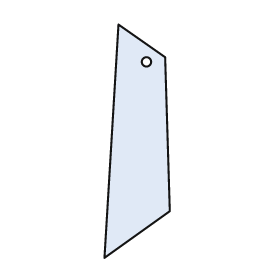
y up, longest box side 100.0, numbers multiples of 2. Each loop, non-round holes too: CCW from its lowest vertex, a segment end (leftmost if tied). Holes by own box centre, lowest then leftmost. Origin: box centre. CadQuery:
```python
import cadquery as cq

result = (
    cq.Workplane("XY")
    .moveTo(-14.0, -50.0)
    .lineTo(14.0, -30.0)
    .lineTo(12.0, 36.0)
    .lineTo(-8.0, 50.0)
    .close()
    .moveTo(4.0, 34.0)
    .circle(2.0)
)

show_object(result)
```